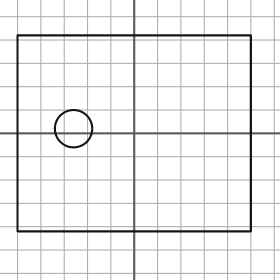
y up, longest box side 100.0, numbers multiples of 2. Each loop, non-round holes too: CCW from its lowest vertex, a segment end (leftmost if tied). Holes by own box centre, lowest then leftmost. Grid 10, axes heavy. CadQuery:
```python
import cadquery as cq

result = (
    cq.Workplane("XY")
    .moveTo(-50.0, -42.0)
    .lineTo(50.0, -42.0)
    .lineTo(50.0, 42.0)
    .lineTo(-50.0, 42.0)
    .close()
    .moveTo(-26.0, 2.0)
    .circle(8.0)
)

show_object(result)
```